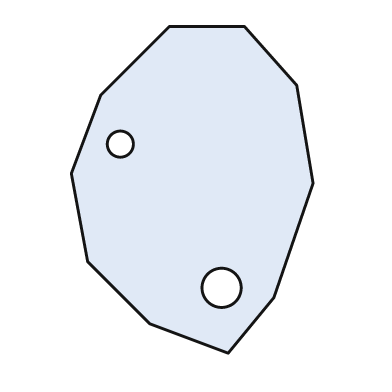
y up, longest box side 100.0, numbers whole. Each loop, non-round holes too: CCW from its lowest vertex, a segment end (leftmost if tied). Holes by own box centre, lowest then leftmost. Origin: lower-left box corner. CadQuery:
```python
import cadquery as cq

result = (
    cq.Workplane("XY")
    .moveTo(48.0, 0.0)
    .lineTo(62.0, 17.0)
    .lineTo(74.0, 52.0)
    .lineTo(69.0, 82.0)
    .lineTo(53.0, 100.0)
    .lineTo(30.0, 100.0)
    .lineTo(9.0, 79.0)
    .lineTo(0.0, 55.0)
    .lineTo(5.0, 28.0)
    .lineTo(24.0, 9.0)
    .close()
    .moveTo(46.0, 20.0)
    .circle(6.0)
    .moveTo(15.0, 64.0)
    .circle(4.0)
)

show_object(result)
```